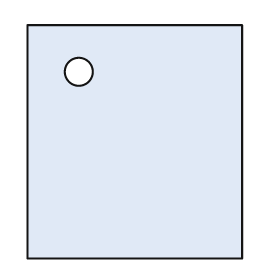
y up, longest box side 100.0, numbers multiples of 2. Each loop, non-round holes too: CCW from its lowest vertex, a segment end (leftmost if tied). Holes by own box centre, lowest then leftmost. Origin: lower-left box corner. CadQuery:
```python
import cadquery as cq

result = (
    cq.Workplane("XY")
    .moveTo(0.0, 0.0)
    .lineTo(92.0, 0.0)
    .lineTo(92.0, 100.0)
    .lineTo(0.0, 100.0)
    .close()
    .moveTo(22.0, 80.0)
    .circle(6.0)
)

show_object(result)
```